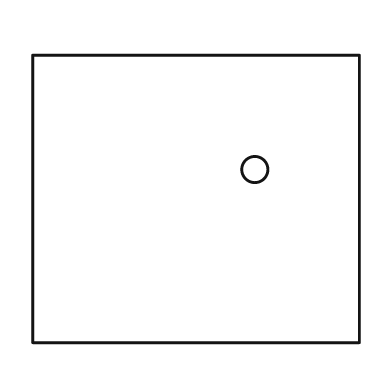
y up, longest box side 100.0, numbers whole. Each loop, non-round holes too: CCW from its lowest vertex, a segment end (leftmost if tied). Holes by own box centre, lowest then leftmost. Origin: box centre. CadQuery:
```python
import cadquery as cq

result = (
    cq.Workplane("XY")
    .moveTo(-50.0, -44.0)
    .lineTo(50.0, -44.0)
    .lineTo(50.0, 44.0)
    .lineTo(-50.0, 44.0)
    .close()
    .moveTo(18.0, 9.0)
    .circle(4.0)
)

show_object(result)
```